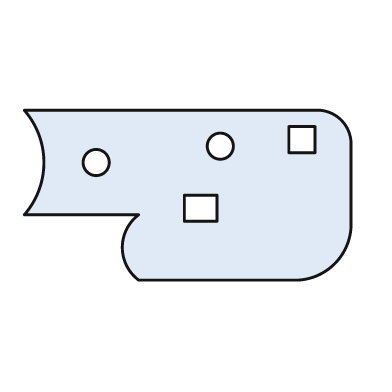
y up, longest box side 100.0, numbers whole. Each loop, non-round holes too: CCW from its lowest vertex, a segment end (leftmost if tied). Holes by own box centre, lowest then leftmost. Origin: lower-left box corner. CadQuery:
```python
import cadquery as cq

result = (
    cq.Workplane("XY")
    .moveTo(35.0, 0.0)
    .lineTo(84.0, 0.0)
    .threePointArc((95.0, 5.0), (100.0, 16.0))
    .lineTo(100.0, 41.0)
    .threePointArc((97.0, 49.0), (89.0, 52.0))
    .lineTo(0.0, 52.0)
    .threePointArc((6.0, 36.0), (0.0, 20.0))
    .lineTo(35.0, 20.0)
    .threePointArc((30.0, 10.0), (35.0, 0.0))
    .close()
    .moveTo(49.0, 18.0)
    .lineTo(59.0, 18.0)
    .lineTo(59.0, 26.0)
    .lineTo(49.0, 26.0)
    .close()
    .moveTo(22.0, 36.0)
    .circle(4.0)
    .moveTo(60.0, 41.0)
    .circle(4.0)
    .moveTo(81.0, 39.0)
    .lineTo(89.0, 39.0)
    .lineTo(89.0, 47.0)
    .lineTo(81.0, 47.0)
    .close()
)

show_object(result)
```